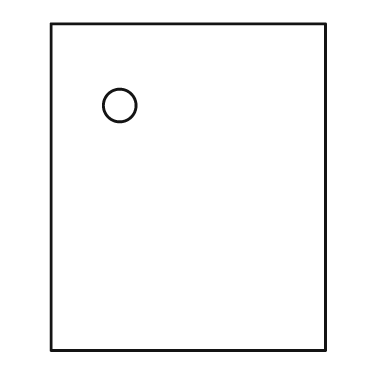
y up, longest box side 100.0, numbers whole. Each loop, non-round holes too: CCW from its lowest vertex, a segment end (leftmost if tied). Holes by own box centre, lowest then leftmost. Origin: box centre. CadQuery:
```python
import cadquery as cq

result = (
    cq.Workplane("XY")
    .moveTo(-42.0, -50.0)
    .lineTo(42.0, -50.0)
    .lineTo(42.0, 50.0)
    .lineTo(-42.0, 50.0)
    .close()
    .moveTo(-21.0, 25.0)
    .circle(5.0)
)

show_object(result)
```